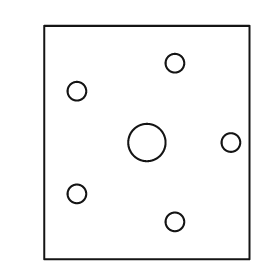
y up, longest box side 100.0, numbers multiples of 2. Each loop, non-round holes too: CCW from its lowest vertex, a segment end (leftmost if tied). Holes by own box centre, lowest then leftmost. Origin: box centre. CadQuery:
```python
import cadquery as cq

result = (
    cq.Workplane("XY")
    .moveTo(-44.0, -50.0)
    .lineTo(44.0, -50.0)
    .lineTo(44.0, 50.0)
    .lineTo(-44.0, 50.0)
    .close()
    .moveTo(12.0, -34.0)
    .circle(4.0)
    .moveTo(-30.0, -22.0)
    .circle(4.0)
    .moveTo(0.0, 0.0)
    .circle(8.0)
    .moveTo(36.0, 0.0)
    .circle(4.0)
    .moveTo(-30.0, 22.0)
    .circle(4.0)
    .moveTo(12.0, 34.0)
    .circle(4.0)
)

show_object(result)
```